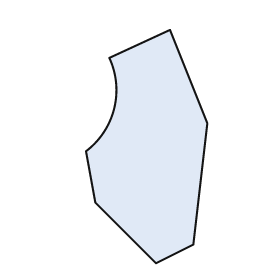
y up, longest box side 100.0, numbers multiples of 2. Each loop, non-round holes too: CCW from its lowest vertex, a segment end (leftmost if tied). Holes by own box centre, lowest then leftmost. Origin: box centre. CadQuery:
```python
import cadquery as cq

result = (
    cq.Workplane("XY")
    .moveTo(4.0, -50.0)
    .lineTo(20.0, -42.0)
    .lineTo(26.0, 10.0)
    .lineTo(10.0, 50.0)
    .lineTo(-16.0, 38.0)
    .threePointArc((-14.0, 16.0), (-26.0, -2.0))
    .lineTo(-22.0, -24.0)
    .close()
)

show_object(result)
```